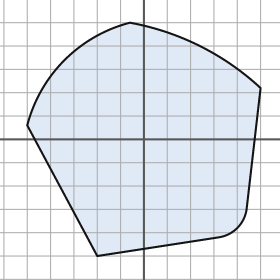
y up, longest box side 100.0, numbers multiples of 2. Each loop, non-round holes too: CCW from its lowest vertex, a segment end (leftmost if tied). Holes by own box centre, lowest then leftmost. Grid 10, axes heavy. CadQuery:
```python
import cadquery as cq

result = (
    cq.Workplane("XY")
    .moveTo(-20.0, -50.0)
    .lineTo(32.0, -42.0)
    .threePointArc((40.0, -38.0), (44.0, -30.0))
    .lineTo(50.0, 22.0)
    .threePointArc((24.0, 40.0), (-6.0, 50.0))
    .threePointArc((-34.0, 34.0), (-50.0, 6.0))
    .close()
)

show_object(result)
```